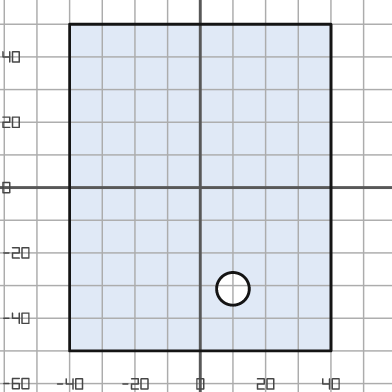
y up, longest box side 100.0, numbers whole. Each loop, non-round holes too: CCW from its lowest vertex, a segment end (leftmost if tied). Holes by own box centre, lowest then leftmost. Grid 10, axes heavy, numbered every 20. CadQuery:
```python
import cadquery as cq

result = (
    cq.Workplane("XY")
    .moveTo(-40.0, -50.0)
    .lineTo(40.0, -50.0)
    .lineTo(40.0, 50.0)
    .lineTo(-40.0, 50.0)
    .close()
    .moveTo(10.0, -31.0)
    .circle(5.0)
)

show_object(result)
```